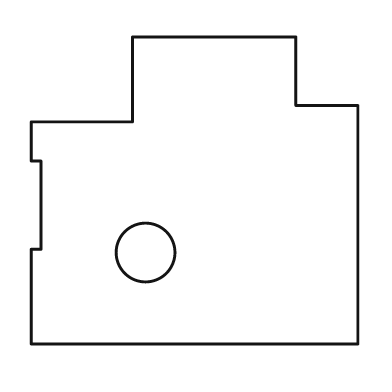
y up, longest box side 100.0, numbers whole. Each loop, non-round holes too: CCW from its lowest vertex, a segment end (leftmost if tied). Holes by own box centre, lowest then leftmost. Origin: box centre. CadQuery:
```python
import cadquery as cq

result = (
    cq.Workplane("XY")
    .moveTo(-50.0, -47.0)
    .lineTo(50.0, -47.0)
    .lineTo(50.0, 26.0)
    .lineTo(31.0, 26.0)
    .lineTo(31.0, 47.0)
    .lineTo(-19.0, 47.0)
    .lineTo(-19.0, 21.0)
    .lineTo(-50.0, 21.0)
    .lineTo(-50.0, 9.0)
    .lineTo(-47.0, 9.0)
    .lineTo(-47.0, -18.0)
    .lineTo(-50.0, -18.0)
    .close()
    .moveTo(-15.0, -19.0)
    .circle(9.0)
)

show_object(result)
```